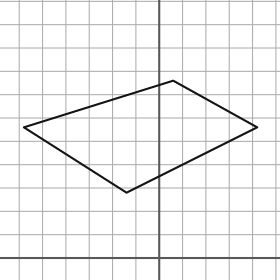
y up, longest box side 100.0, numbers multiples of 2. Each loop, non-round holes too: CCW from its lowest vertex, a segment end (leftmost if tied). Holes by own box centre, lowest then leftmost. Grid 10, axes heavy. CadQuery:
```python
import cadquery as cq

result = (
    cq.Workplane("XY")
    .moveTo(-14.0, 28.0)
    .lineTo(42.0, 56.0)
    .lineTo(6.0, 76.0)
    .lineTo(-58.0, 56.0)
    .close()
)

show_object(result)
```